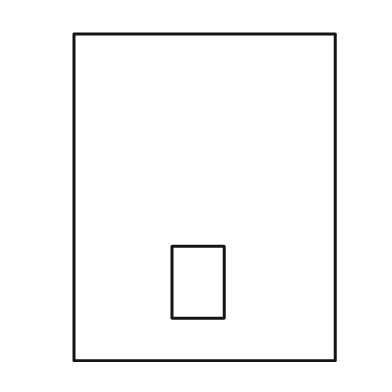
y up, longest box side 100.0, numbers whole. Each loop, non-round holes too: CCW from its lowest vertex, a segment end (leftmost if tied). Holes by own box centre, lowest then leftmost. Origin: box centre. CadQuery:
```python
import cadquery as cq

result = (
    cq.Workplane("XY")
    .moveTo(-40.0, -50.0)
    .lineTo(40.0, -50.0)
    .lineTo(40.0, 50.0)
    .lineTo(-40.0, 50.0)
    .close()
    .moveTo(-10.0, -37.0)
    .lineTo(6.0, -37.0)
    .lineTo(6.0, -15.0)
    .lineTo(-10.0, -15.0)
    .close()
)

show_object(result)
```